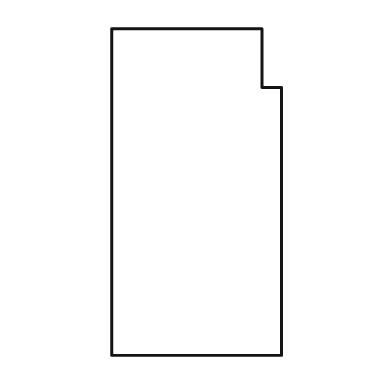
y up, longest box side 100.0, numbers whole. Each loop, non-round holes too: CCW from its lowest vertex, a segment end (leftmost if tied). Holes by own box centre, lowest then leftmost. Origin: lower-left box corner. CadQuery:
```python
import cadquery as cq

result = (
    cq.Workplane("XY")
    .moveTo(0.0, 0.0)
    .lineTo(52.0, 0.0)
    .lineTo(52.0, 82.0)
    .lineTo(46.0, 82.0)
    .lineTo(46.0, 100.0)
    .lineTo(0.0, 100.0)
    .close()
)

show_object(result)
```